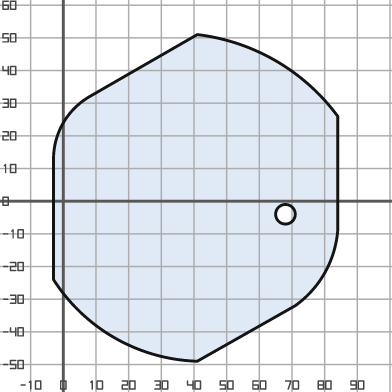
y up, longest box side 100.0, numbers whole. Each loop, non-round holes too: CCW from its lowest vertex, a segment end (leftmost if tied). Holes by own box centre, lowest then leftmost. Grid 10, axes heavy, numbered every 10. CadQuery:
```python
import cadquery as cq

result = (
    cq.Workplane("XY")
    .moveTo(41.0, -49.0)
    .lineTo(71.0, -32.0)
    .threePointArc((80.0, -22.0), (84.0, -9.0))
    .lineTo(84.0, 26.0)
    .threePointArc((65.0, 43.0), (41.0, 51.0))
    .lineTo(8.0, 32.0)
    .threePointArc((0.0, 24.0), (-3.0, 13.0))
    .lineTo(-3.0, -24.0)
    .threePointArc((16.0, -42.0), (41.0, -49.0))
    .close()
    .moveTo(68.0, -4.0)
    .circle(3.0)
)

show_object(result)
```